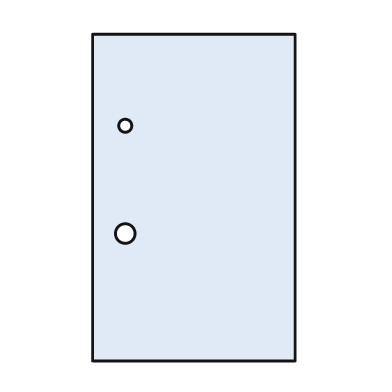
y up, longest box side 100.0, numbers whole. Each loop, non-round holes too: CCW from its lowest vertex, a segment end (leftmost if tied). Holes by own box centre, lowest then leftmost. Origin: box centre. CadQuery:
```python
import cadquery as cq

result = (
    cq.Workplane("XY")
    .moveTo(-31.0, -50.0)
    .lineTo(31.0, -50.0)
    .lineTo(31.0, 50.0)
    .lineTo(-31.0, 50.0)
    .close()
    .moveTo(-21.0, -11.0)
    .circle(3.0)
    .moveTo(-21.0, 22.0)
    .circle(2.0)
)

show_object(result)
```